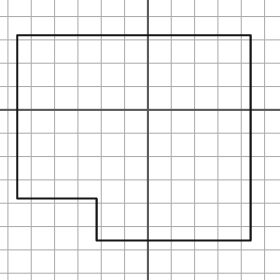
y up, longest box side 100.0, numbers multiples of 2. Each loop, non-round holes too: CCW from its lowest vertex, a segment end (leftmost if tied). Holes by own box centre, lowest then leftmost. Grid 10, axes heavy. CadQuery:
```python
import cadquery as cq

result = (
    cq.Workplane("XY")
    .moveTo(-22.0, -56.0)
    .lineTo(44.0, -56.0)
    .lineTo(44.0, 32.0)
    .lineTo(-56.0, 32.0)
    .lineTo(-56.0, -38.0)
    .lineTo(-22.0, -38.0)
    .close()
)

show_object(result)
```